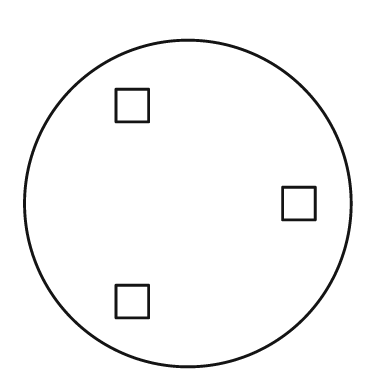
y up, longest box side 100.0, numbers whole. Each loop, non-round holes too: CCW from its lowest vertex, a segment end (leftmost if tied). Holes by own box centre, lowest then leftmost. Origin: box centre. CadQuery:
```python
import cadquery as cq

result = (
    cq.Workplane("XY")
    .moveTo(0.0, 0.0)
    .circle(50.0)
    .moveTo(-22.0, -35.0)
    .lineTo(-12.0, -35.0)
    .lineTo(-12.0, -25.0)
    .lineTo(-22.0, -25.0)
    .close()
    .moveTo(29.0, -5.0)
    .lineTo(39.0, -5.0)
    .lineTo(39.0, 5.0)
    .lineTo(29.0, 5.0)
    .close()
    .moveTo(-22.0, 25.0)
    .lineTo(-12.0, 25.0)
    .lineTo(-12.0, 35.0)
    .lineTo(-22.0, 35.0)
    .close()
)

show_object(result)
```